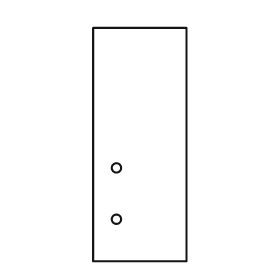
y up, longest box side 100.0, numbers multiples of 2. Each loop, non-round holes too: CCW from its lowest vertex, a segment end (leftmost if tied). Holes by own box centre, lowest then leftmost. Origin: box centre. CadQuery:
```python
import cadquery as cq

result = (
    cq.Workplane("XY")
    .moveTo(-20.0, -50.0)
    .lineTo(20.0, -50.0)
    .lineTo(20.0, 50.0)
    .lineTo(-20.0, 50.0)
    .close()
    .moveTo(-10.0, -32.0)
    .circle(2.0)
    .moveTo(-10.0, -10.0)
    .circle(2.0)
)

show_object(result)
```